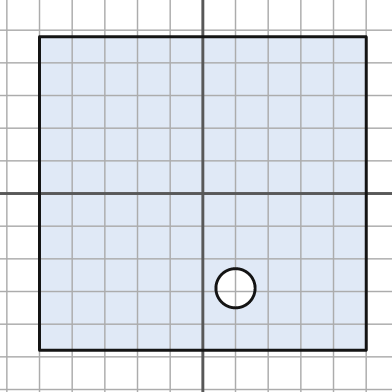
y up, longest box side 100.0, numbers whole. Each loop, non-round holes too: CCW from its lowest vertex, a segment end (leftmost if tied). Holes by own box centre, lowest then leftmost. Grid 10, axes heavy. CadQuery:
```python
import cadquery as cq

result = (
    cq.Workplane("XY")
    .moveTo(-50.0, -48.0)
    .lineTo(50.0, -48.0)
    .lineTo(50.0, 48.0)
    .lineTo(-50.0, 48.0)
    .close()
    .moveTo(10.0, -29.0)
    .circle(6.0)
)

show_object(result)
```